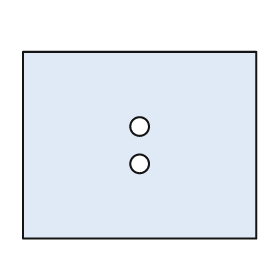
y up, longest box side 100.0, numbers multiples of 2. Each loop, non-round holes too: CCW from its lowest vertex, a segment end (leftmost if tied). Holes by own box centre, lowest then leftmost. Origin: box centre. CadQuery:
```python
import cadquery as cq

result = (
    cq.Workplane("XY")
    .moveTo(-50.0, -40.0)
    .lineTo(50.0, -40.0)
    .lineTo(50.0, 40.0)
    .lineTo(-50.0, 40.0)
    .close()
    .moveTo(0.0, -8.0)
    .circle(4.0)
    .moveTo(0.0, 8.0)
    .circle(4.0)
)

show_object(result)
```